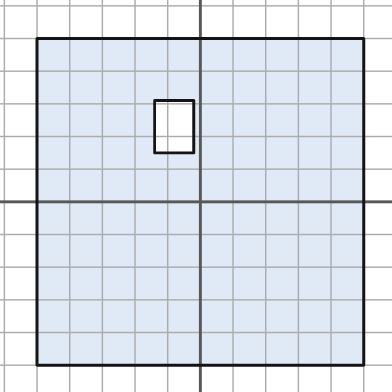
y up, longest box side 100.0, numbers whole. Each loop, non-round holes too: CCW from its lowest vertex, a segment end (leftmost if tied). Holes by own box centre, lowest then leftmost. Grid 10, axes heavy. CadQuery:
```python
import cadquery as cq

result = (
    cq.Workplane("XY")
    .moveTo(-50.0, -50.0)
    .lineTo(50.0, -50.0)
    .lineTo(50.0, 50.0)
    .lineTo(-50.0, 50.0)
    .close()
    .moveTo(-14.0, 15.0)
    .lineTo(-2.0, 15.0)
    .lineTo(-2.0, 31.0)
    .lineTo(-14.0, 31.0)
    .close()
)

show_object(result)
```